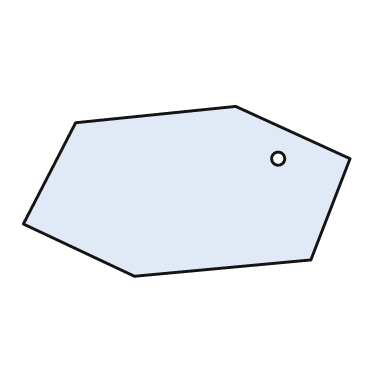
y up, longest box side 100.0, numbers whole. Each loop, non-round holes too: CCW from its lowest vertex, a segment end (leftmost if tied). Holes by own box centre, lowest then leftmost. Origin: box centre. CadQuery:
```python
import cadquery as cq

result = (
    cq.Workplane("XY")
    .moveTo(-16.0, -26.0)
    .lineTo(38.0, -21.0)
    .lineTo(50.0, 10.0)
    .lineTo(15.0, 26.0)
    .lineTo(-34.0, 21.0)
    .lineTo(-50.0, -10.0)
    .close()
    .moveTo(28.0, 10.0)
    .circle(2.0)
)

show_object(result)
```